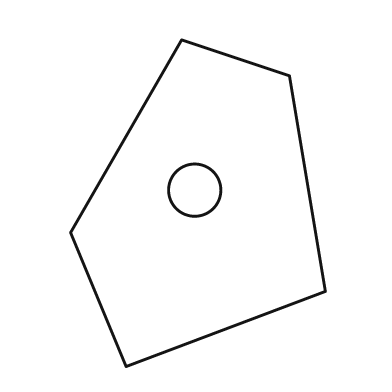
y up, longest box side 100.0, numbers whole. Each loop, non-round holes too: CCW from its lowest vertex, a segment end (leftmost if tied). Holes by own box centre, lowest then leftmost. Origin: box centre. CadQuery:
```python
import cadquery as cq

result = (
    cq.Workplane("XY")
    .moveTo(-22.0, -50.0)
    .lineTo(39.0, -27.0)
    .lineTo(28.0, 39.0)
    .lineTo(-5.0, 50.0)
    .lineTo(-39.0, -9.0)
    .close()
    .moveTo(-1.0, 4.0)
    .circle(8.0)
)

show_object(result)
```